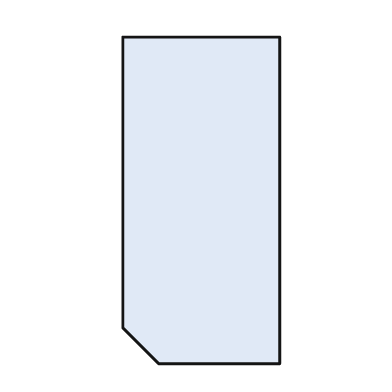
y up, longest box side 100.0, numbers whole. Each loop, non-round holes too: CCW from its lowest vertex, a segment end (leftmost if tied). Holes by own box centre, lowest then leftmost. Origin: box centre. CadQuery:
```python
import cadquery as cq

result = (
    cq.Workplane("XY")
    .moveTo(-13.0, -50.0)
    .lineTo(24.0, -50.0)
    .lineTo(24.0, 50.0)
    .lineTo(-24.0, 50.0)
    .lineTo(-24.0, -39.0)
    .close()
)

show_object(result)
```